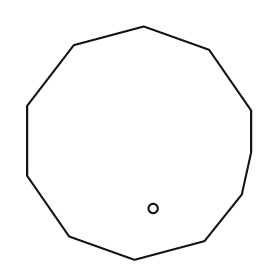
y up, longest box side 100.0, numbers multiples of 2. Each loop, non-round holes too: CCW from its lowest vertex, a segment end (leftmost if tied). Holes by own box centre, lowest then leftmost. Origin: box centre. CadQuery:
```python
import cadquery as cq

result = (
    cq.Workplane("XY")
    .moveTo(-2.0, -50.0)
    .lineTo(28.0, -42.0)
    .lineTo(44.0, -22.0)
    .lineTo(48.0, -4.0)
    .lineTo(48.0, 14.0)
    .lineTo(30.0, 40.0)
    .lineTo(2.0, 50.0)
    .lineTo(-28.0, 42.0)
    .lineTo(-48.0, 16.0)
    .lineTo(-48.0, -14.0)
    .lineTo(-30.0, -40.0)
    .close()
    .moveTo(6.0, -28.0)
    .circle(2.0)
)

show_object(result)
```